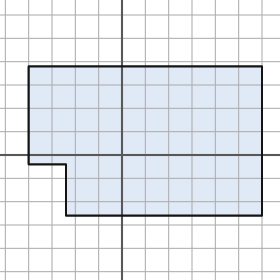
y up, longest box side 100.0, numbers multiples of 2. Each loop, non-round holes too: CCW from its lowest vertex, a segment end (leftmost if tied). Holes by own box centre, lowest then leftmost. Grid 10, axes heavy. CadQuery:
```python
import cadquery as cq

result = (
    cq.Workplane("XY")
    .moveTo(-24.0, -26.0)
    .lineTo(60.0, -26.0)
    .lineTo(60.0, 38.0)
    .lineTo(-40.0, 38.0)
    .lineTo(-40.0, -4.0)
    .lineTo(-24.0, -4.0)
    .close()
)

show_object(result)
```